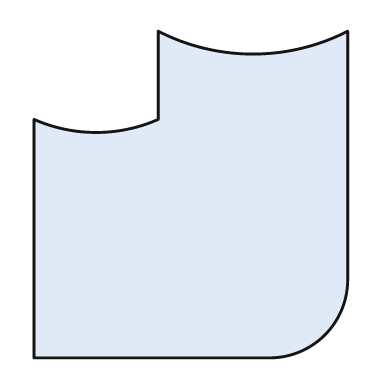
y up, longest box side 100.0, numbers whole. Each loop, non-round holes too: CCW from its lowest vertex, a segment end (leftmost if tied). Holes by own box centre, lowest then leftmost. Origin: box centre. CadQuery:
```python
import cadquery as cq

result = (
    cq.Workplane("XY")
    .moveTo(-48.0, -50.0)
    .lineTo(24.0, -50.0)
    .threePointArc((41.0, -43.0), (48.0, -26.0))
    .lineTo(48.0, 50.0)
    .threePointArc((19.0, 43.0), (-10.0, 50.0))
    .lineTo(-10.0, 23.0)
    .threePointArc((-29.0, 19.0), (-48.0, 23.0))
    .close()
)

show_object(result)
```